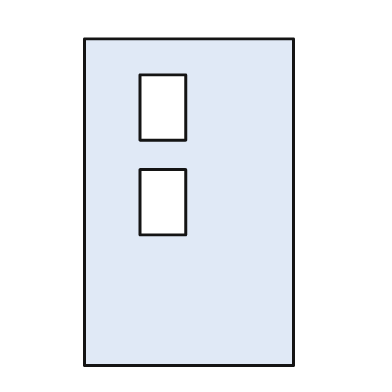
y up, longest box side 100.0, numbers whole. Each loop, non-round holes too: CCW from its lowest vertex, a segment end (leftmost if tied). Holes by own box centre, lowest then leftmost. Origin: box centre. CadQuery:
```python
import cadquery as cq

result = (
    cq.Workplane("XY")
    .moveTo(-32.0, -50.0)
    .lineTo(32.0, -50.0)
    .lineTo(32.0, 50.0)
    .lineTo(-32.0, 50.0)
    .close()
    .moveTo(-15.0, -10.0)
    .lineTo(-1.0, -10.0)
    .lineTo(-1.0, 10.0)
    .lineTo(-15.0, 10.0)
    .close()
    .moveTo(-15.0, 19.0)
    .lineTo(-1.0, 19.0)
    .lineTo(-1.0, 39.0)
    .lineTo(-15.0, 39.0)
    .close()
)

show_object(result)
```